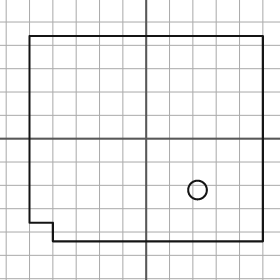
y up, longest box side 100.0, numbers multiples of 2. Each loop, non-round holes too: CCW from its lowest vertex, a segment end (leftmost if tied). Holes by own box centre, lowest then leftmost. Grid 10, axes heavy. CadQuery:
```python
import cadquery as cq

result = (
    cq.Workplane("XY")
    .moveTo(-40.0, -44.0)
    .lineTo(50.0, -44.0)
    .lineTo(50.0, 44.0)
    .lineTo(-50.0, 44.0)
    .lineTo(-50.0, -36.0)
    .lineTo(-40.0, -36.0)
    .close()
    .moveTo(22.0, -22.0)
    .circle(4.0)
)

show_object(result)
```